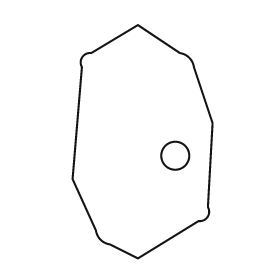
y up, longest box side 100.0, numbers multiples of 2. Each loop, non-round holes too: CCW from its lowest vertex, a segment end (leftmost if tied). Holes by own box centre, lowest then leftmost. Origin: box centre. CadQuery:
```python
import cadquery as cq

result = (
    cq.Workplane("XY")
    .moveTo(-2.0, -50.0)
    .lineTo(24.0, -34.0)
    .threePointArc((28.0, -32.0), (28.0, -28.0))
    .lineTo(30.0, 8.0)
    .lineTo(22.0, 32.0)
    .threePointArc((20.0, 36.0), (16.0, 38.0))
    .lineTo(-2.0, 50.0)
    .lineTo(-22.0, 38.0)
    .threePointArc((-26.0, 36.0), (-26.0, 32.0))
    .lineTo(-30.0, -16.0)
    .lineTo(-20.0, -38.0)
    .threePointArc((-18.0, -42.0), (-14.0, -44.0))
    .close()
    .moveTo(14.0, -6.0)
    .circle(6.0)
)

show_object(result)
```